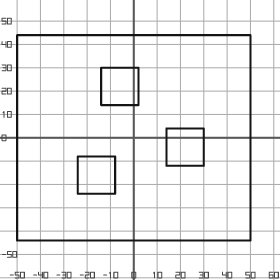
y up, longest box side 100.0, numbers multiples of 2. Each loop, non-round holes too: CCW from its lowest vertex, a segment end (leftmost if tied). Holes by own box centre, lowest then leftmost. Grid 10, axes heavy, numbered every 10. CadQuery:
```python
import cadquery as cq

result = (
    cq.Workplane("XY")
    .moveTo(-50.0, -44.0)
    .lineTo(50.0, -44.0)
    .lineTo(50.0, 44.0)
    .lineTo(-50.0, 44.0)
    .close()
    .moveTo(-24.0, -24.0)
    .lineTo(-8.0, -24.0)
    .lineTo(-8.0, -8.0)
    .lineTo(-24.0, -8.0)
    .close()
    .moveTo(14.0, -12.0)
    .lineTo(30.0, -12.0)
    .lineTo(30.0, 4.0)
    .lineTo(14.0, 4.0)
    .close()
    .moveTo(-14.0, 14.0)
    .lineTo(2.0, 14.0)
    .lineTo(2.0, 30.0)
    .lineTo(-14.0, 30.0)
    .close()
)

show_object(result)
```